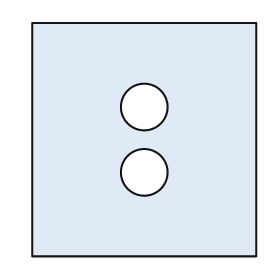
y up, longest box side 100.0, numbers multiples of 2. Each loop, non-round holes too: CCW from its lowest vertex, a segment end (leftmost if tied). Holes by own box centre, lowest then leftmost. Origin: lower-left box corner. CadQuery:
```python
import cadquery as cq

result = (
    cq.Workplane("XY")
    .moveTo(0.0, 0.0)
    .lineTo(96.0, 0.0)
    .lineTo(96.0, 100.0)
    .lineTo(0.0, 100.0)
    .close()
    .moveTo(48.0, 36.0)
    .circle(10.0)
    .moveTo(48.0, 64.0)
    .circle(10.0)
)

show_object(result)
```